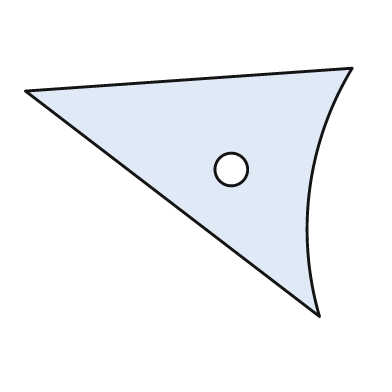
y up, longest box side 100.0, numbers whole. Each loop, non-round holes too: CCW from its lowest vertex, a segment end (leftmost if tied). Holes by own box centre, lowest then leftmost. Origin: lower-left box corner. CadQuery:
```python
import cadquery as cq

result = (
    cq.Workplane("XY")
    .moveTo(90.0, 0.0)
    .threePointArc((87.0, 39.0), (100.0, 76.0))
    .lineTo(0.0, 69.0)
    .close()
    .moveTo(63.0, 45.0)
    .circle(5.0)
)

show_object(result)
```